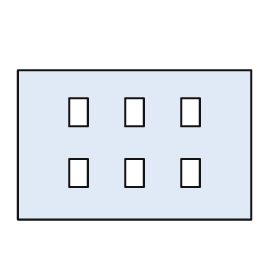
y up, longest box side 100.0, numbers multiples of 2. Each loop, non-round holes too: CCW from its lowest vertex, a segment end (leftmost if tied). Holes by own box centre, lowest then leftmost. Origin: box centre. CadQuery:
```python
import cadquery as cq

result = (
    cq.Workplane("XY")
    .moveTo(-50.0, -32.0)
    .lineTo(50.0, -32.0)
    .lineTo(50.0, 32.0)
    .lineTo(-50.0, 32.0)
    .close()
    .moveTo(-28.0, -18.0)
    .lineTo(-20.0, -18.0)
    .lineTo(-20.0, -6.0)
    .lineTo(-28.0, -6.0)
    .close()
    .moveTo(-4.0, -18.0)
    .lineTo(4.0, -18.0)
    .lineTo(4.0, -6.0)
    .lineTo(-4.0, -6.0)
    .close()
    .moveTo(20.0, -18.0)
    .lineTo(28.0, -18.0)
    .lineTo(28.0, -6.0)
    .lineTo(20.0, -6.0)
    .close()
    .moveTo(-28.0, 8.0)
    .lineTo(-20.0, 8.0)
    .lineTo(-20.0, 20.0)
    .lineTo(-28.0, 20.0)
    .close()
    .moveTo(-4.0, 8.0)
    .lineTo(4.0, 8.0)
    .lineTo(4.0, 20.0)
    .lineTo(-4.0, 20.0)
    .close()
    .moveTo(20.0, 8.0)
    .lineTo(28.0, 8.0)
    .lineTo(28.0, 20.0)
    .lineTo(20.0, 20.0)
    .close()
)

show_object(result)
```